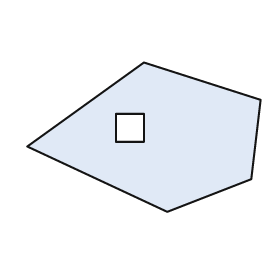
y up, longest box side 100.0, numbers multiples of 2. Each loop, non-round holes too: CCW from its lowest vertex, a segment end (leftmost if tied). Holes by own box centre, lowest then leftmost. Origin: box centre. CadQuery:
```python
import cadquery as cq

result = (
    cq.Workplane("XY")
    .moveTo(10.0, -32.0)
    .lineTo(46.0, -18.0)
    .lineTo(50.0, 16.0)
    .lineTo(0.0, 32.0)
    .lineTo(-50.0, -4.0)
    .close()
    .moveTo(-12.0, -2.0)
    .lineTo(0.0, -2.0)
    .lineTo(0.0, 10.0)
    .lineTo(-12.0, 10.0)
    .close()
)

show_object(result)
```